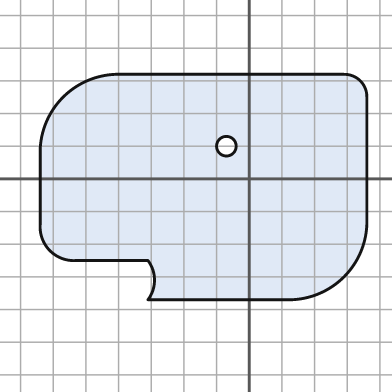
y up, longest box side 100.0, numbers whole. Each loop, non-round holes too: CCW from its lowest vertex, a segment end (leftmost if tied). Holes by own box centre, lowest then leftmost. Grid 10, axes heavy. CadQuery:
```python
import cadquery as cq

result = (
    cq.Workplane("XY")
    .moveTo(-31.0, -37.0)
    .lineTo(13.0, -37.0)
    .threePointArc((29.0, -30.0), (36.0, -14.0))
    .lineTo(36.0, 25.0)
    .threePointArc((34.0, 30.0), (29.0, 32.0))
    .lineTo(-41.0, 32.0)
    .threePointArc((-57.0, 25.0), (-64.0, 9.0))
    .lineTo(-64.0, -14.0)
    .threePointArc((-61.0, -22.0), (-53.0, -25.0))
    .lineTo(-31.0, -25.0)
    .threePointArc((-29.0, -31.0), (-31.0, -37.0))
    .close()
    .moveTo(-7.0, 10.0)
    .circle(3.0)
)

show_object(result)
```